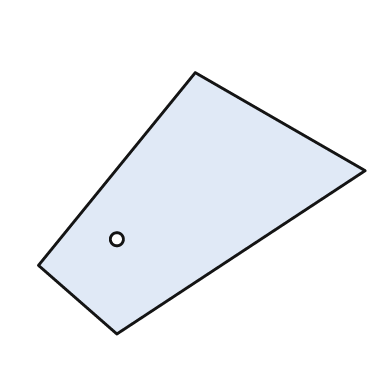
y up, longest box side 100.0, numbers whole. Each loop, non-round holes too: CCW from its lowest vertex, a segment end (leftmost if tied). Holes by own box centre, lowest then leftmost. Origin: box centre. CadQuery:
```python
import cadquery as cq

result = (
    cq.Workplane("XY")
    .moveTo(-26.0, -40.0)
    .lineTo(50.0, 10.0)
    .lineTo(-2.0, 40.0)
    .lineTo(-50.0, -19.0)
    .close()
    .moveTo(-26.0, -11.0)
    .circle(2.0)
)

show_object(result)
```